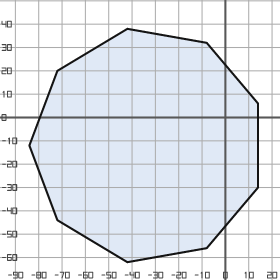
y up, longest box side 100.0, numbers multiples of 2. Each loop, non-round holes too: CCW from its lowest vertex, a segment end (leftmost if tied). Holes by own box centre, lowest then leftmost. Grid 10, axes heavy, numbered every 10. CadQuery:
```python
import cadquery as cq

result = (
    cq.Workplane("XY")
    .moveTo(-42.0, -62.0)
    .lineTo(-8.0, -56.0)
    .lineTo(14.0, -30.0)
    .lineTo(14.0, 6.0)
    .lineTo(-8.0, 32.0)
    .lineTo(-42.0, 38.0)
    .lineTo(-72.0, 20.0)
    .lineTo(-84.0, -12.0)
    .lineTo(-72.0, -44.0)
    .close()
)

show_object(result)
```